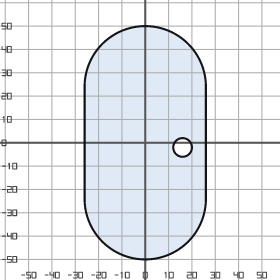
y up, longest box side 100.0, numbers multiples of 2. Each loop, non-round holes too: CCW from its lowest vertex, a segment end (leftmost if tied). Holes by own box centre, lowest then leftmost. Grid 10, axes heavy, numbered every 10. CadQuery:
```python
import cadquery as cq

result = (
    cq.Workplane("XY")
    .moveTo(-26.0, -24.0)
    .threePointArc((0.0, -50.0), (26.0, -24.0))
    .lineTo(26.0, 24.0)
    .threePointArc((0.0, 50.0), (-26.0, 24.0))
    .close()
    .moveTo(16.0, -2.0)
    .circle(4.0)
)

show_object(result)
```